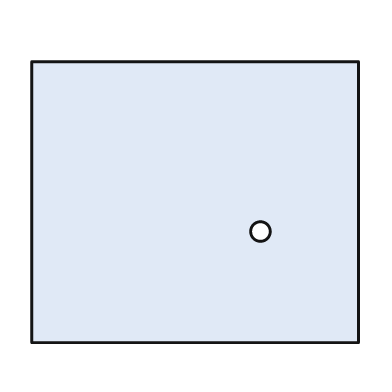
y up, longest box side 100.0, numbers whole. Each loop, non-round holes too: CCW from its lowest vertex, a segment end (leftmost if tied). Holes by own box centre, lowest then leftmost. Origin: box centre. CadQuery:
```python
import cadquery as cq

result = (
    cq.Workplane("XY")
    .moveTo(-50.0, -43.0)
    .lineTo(50.0, -43.0)
    .lineTo(50.0, 43.0)
    .lineTo(-50.0, 43.0)
    .close()
    .moveTo(20.0, -9.0)
    .circle(3.0)
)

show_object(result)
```